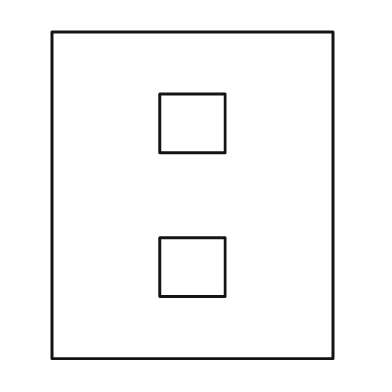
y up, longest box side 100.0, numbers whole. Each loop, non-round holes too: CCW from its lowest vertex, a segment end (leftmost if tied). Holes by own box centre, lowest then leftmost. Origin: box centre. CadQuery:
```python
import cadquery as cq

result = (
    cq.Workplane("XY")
    .moveTo(-43.0, -50.0)
    .lineTo(43.0, -50.0)
    .lineTo(43.0, 50.0)
    .lineTo(-43.0, 50.0)
    .close()
    .moveTo(-10.0, -31.0)
    .lineTo(10.0, -31.0)
    .lineTo(10.0, -13.0)
    .lineTo(-10.0, -13.0)
    .close()
    .moveTo(-10.0, 13.0)
    .lineTo(10.0, 13.0)
    .lineTo(10.0, 31.0)
    .lineTo(-10.0, 31.0)
    .close()
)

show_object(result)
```